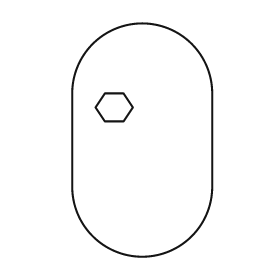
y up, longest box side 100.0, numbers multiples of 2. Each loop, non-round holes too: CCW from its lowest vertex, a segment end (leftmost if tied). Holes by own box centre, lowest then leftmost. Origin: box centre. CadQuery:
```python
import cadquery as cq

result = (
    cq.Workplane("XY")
    .moveTo(-30.0, -20.0)
    .threePointArc((0.0, -50.0), (30.0, -20.0))
    .lineTo(30.0, 20.0)
    .threePointArc((0.0, 50.0), (-30.0, 20.0))
    .close()
    .moveTo(-16.0, 8.0)
    .lineTo(-8.0, 8.0)
    .lineTo(-4.0, 14.0)
    .lineTo(-8.0, 20.0)
    .lineTo(-16.0, 20.0)
    .lineTo(-20.0, 14.0)
    .close()
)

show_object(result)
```